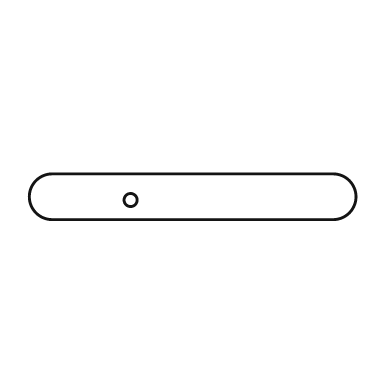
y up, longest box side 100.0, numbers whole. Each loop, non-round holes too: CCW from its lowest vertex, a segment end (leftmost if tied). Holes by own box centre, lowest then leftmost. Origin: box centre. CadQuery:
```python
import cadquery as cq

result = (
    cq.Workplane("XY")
    .moveTo(-43.0, -7.0)
    .lineTo(43.0, -7.0)
    .threePointArc((50.0, 0.0), (43.0, 7.0))
    .lineTo(-43.0, 7.0)
    .threePointArc((-50.0, 0.0), (-43.0, -7.0))
    .close()
    .moveTo(-19.0, -1.0)
    .circle(2.0)
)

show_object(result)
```